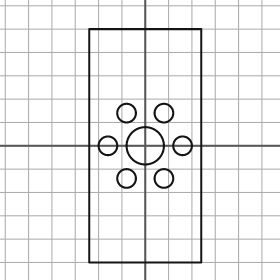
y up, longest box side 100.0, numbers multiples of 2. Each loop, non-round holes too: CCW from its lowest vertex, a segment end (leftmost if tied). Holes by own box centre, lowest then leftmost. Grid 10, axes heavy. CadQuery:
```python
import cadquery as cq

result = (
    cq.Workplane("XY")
    .moveTo(-24.0, -50.0)
    .lineTo(24.0, -50.0)
    .lineTo(24.0, 50.0)
    .lineTo(-24.0, 50.0)
    .close()
    .moveTo(-8.0, -14.0)
    .circle(4.0)
    .moveTo(8.0, -14.0)
    .circle(4.0)
    .moveTo(-16.0, 0.0)
    .circle(4.0)
    .moveTo(0.0, 0.0)
    .circle(8.0)
    .moveTo(16.0, 0.0)
    .circle(4.0)
    .moveTo(-8.0, 14.0)
    .circle(4.0)
    .moveTo(8.0, 14.0)
    .circle(4.0)
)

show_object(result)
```